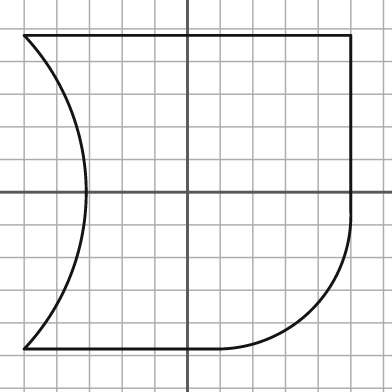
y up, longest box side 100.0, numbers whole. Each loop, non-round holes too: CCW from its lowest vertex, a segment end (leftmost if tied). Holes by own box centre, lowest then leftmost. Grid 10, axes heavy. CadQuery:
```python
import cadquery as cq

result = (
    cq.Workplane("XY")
    .moveTo(-50.0, -48.0)
    .lineTo(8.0, -48.0)
    .threePointArc((38.0, -36.0), (50.0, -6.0))
    .lineTo(50.0, 48.0)
    .lineTo(-50.0, 48.0)
    .threePointArc((-31.0, 0.0), (-50.0, -48.0))
    .close()
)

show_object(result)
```